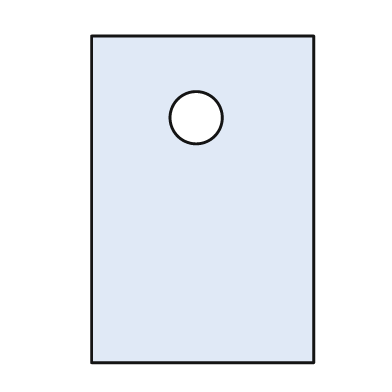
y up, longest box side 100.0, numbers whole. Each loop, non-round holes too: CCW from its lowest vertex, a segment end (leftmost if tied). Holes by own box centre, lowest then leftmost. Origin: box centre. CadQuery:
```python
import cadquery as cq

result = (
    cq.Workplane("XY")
    .moveTo(-34.0, -50.0)
    .lineTo(34.0, -50.0)
    .lineTo(34.0, 50.0)
    .lineTo(-34.0, 50.0)
    .close()
    .moveTo(-2.0, 25.0)
    .circle(8.0)
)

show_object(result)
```